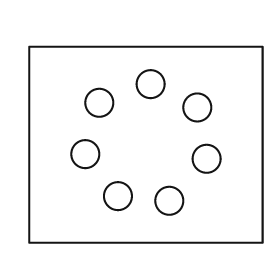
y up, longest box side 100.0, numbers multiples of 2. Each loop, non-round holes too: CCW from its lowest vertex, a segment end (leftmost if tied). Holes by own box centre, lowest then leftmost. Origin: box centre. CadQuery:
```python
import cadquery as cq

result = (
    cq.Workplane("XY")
    .moveTo(-50.0, -42.0)
    .lineTo(50.0, -42.0)
    .lineTo(50.0, 42.0)
    .lineTo(-50.0, 42.0)
    .close()
    .moveTo(10.0, -24.0)
    .circle(6.0)
    .moveTo(-12.0, -22.0)
    .circle(6.0)
    .moveTo(26.0, -6.0)
    .circle(6.0)
    .moveTo(-26.0, -4.0)
    .circle(6.0)
    .moveTo(22.0, 16.0)
    .circle(6.0)
    .moveTo(-20.0, 18.0)
    .circle(6.0)
    .moveTo(2.0, 26.0)
    .circle(6.0)
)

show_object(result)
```